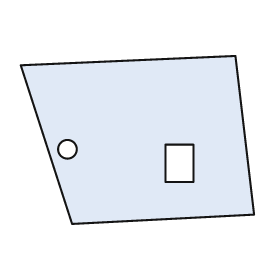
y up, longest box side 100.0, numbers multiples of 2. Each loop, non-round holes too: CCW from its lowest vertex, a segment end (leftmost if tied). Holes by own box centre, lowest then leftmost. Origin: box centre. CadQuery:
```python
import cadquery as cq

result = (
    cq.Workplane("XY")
    .moveTo(-28.0, -36.0)
    .lineTo(50.0, -32.0)
    .lineTo(42.0, 36.0)
    .lineTo(-50.0, 32.0)
    .close()
    .moveTo(12.0, -18.0)
    .lineTo(24.0, -18.0)
    .lineTo(24.0, -2.0)
    .lineTo(12.0, -2.0)
    .close()
    .moveTo(-30.0, -4.0)
    .circle(4.0)
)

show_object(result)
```